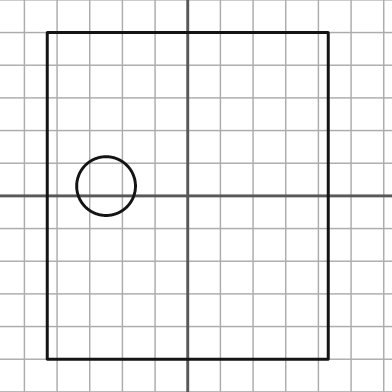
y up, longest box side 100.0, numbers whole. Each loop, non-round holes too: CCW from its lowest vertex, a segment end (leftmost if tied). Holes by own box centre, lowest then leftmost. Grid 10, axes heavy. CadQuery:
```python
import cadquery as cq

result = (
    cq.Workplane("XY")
    .moveTo(-43.0, -50.0)
    .lineTo(43.0, -50.0)
    .lineTo(43.0, 50.0)
    .lineTo(-43.0, 50.0)
    .close()
    .moveTo(-25.0, 3.0)
    .circle(9.0)
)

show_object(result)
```